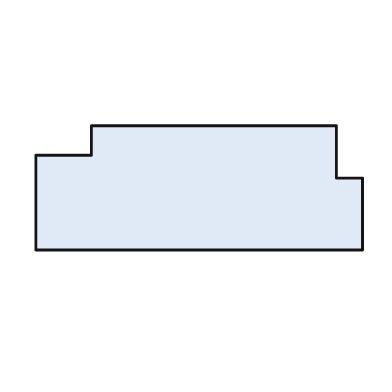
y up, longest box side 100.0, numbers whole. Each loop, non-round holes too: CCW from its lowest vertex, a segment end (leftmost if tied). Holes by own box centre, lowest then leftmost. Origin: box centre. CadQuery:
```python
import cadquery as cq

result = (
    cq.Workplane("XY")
    .moveTo(-50.0, -19.0)
    .lineTo(50.0, -19.0)
    .lineTo(50.0, 3.0)
    .lineTo(42.0, 3.0)
    .lineTo(42.0, 19.0)
    .lineTo(-33.0, 19.0)
    .lineTo(-33.0, 10.0)
    .lineTo(-50.0, 10.0)
    .close()
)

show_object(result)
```